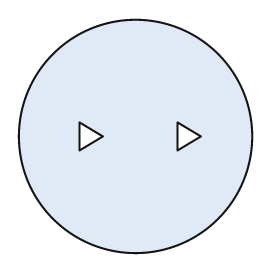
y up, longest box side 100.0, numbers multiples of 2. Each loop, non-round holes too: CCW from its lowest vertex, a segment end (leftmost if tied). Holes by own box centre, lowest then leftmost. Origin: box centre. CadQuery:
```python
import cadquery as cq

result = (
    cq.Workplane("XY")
    .moveTo(0.0, 0.0)
    .circle(50.0)
    .moveTo(-24.0, -6.0)
    .lineTo(-14.0, 0.0)
    .lineTo(-24.0, 6.0)
    .close()
    .moveTo(18.0, -6.0)
    .lineTo(28.0, 0.0)
    .lineTo(18.0, 6.0)
    .close()
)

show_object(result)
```